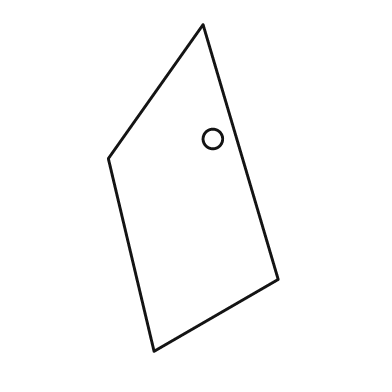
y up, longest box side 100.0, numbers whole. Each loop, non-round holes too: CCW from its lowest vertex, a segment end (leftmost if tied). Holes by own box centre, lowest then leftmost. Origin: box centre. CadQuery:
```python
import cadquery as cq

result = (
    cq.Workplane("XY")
    .moveTo(-12.0, -50.0)
    .lineTo(26.0, -28.0)
    .lineTo(3.0, 50.0)
    .lineTo(-26.0, 9.0)
    .close()
    .moveTo(6.0, 15.0)
    .circle(3.0)
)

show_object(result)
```